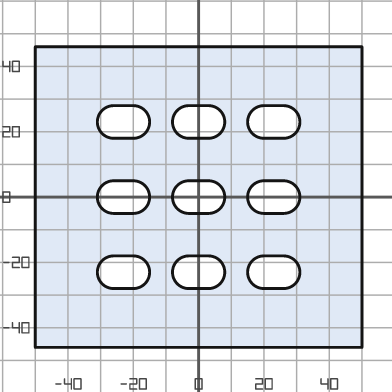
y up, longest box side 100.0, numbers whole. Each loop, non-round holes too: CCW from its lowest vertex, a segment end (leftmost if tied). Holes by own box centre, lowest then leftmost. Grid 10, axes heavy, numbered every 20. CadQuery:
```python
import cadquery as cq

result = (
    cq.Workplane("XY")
    .moveTo(-50.0, -46.0)
    .lineTo(50.0, -46.0)
    .lineTo(50.0, 46.0)
    .lineTo(-50.0, 46.0)
    .close()
    .moveTo(-26.0, -28.0)
    .lineTo(-20.0, -28.0)
    .threePointArc((-15.0, -23.0), (-20.0, -18.0))
    .lineTo(-26.0, -18.0)
    .threePointArc((-31.0, -23.0), (-26.0, -28.0))
    .close()
    .moveTo(-3.0, -28.0)
    .lineTo(3.0, -28.0)
    .threePointArc((8.0, -23.0), (3.0, -18.0))
    .lineTo(-3.0, -18.0)
    .threePointArc((-8.0, -23.0), (-3.0, -28.0))
    .close()
    .moveTo(20.0, -28.0)
    .lineTo(26.0, -28.0)
    .threePointArc((31.0, -23.0), (26.0, -18.0))
    .lineTo(20.0, -18.0)
    .threePointArc((15.0, -23.0), (20.0, -28.0))
    .close()
    .moveTo(-26.0, -5.0)
    .lineTo(-20.0, -5.0)
    .threePointArc((-15.0, 0.0), (-20.0, 5.0))
    .lineTo(-26.0, 5.0)
    .threePointArc((-31.0, 0.0), (-26.0, -5.0))
    .close()
    .moveTo(-3.0, -5.0)
    .lineTo(3.0, -5.0)
    .threePointArc((8.0, 0.0), (3.0, 5.0))
    .lineTo(-3.0, 5.0)
    .threePointArc((-8.0, 0.0), (-3.0, -5.0))
    .close()
    .moveTo(20.0, -5.0)
    .lineTo(26.0, -5.0)
    .threePointArc((31.0, 0.0), (26.0, 5.0))
    .lineTo(20.0, 5.0)
    .threePointArc((15.0, 0.0), (20.0, -5.0))
    .close()
    .moveTo(-26.0, 18.0)
    .lineTo(-20.0, 18.0)
    .threePointArc((-15.0, 23.0), (-20.0, 28.0))
    .lineTo(-26.0, 28.0)
    .threePointArc((-31.0, 23.0), (-26.0, 18.0))
    .close()
    .moveTo(-3.0, 18.0)
    .lineTo(3.0, 18.0)
    .threePointArc((8.0, 23.0), (3.0, 28.0))
    .lineTo(-3.0, 28.0)
    .threePointArc((-8.0, 23.0), (-3.0, 18.0))
    .close()
    .moveTo(20.0, 18.0)
    .lineTo(26.0, 18.0)
    .threePointArc((31.0, 23.0), (26.0, 28.0))
    .lineTo(20.0, 28.0)
    .threePointArc((15.0, 23.0), (20.0, 18.0))
    .close()
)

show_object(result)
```